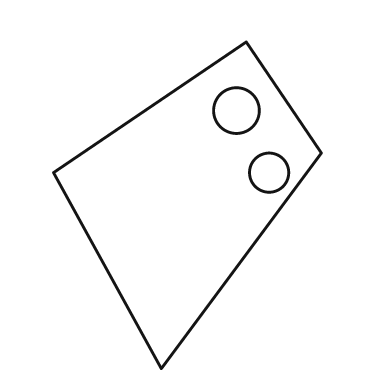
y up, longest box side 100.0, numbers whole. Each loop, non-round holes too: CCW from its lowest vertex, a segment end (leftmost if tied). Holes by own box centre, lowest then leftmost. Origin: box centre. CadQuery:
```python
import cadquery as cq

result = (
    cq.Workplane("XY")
    .moveTo(-8.0, -50.0)
    .lineTo(41.0, 16.0)
    .lineTo(18.0, 50.0)
    .lineTo(-41.0, 10.0)
    .close()
    .moveTo(25.0, 10.0)
    .circle(6.0)
    .moveTo(15.0, 29.0)
    .circle(7.0)
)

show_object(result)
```